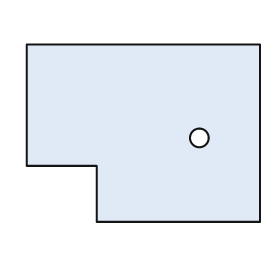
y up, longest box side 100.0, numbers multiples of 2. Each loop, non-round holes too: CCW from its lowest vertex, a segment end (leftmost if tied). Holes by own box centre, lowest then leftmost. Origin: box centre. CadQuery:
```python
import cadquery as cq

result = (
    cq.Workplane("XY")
    .moveTo(-20.0, -38.0)
    .lineTo(50.0, -38.0)
    .lineTo(50.0, 38.0)
    .lineTo(-50.0, 38.0)
    .lineTo(-50.0, -14.0)
    .lineTo(-20.0, -14.0)
    .close()
    .moveTo(24.0, -2.0)
    .circle(4.0)
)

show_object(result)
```